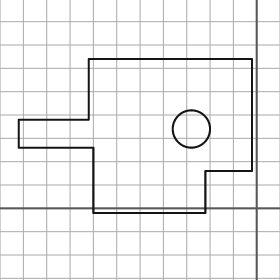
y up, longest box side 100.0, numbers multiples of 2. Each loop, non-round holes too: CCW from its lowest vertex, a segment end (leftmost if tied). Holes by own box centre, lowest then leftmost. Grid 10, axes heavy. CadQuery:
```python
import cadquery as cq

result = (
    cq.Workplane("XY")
    .moveTo(-70.0, -2.0)
    .lineTo(-22.0, -2.0)
    .lineTo(-22.0, 16.0)
    .lineTo(-2.0, 16.0)
    .lineTo(-2.0, 64.0)
    .lineTo(-72.0, 64.0)
    .lineTo(-72.0, 38.0)
    .lineTo(-102.0, 38.0)
    .lineTo(-102.0, 26.0)
    .lineTo(-70.0, 26.0)
    .close()
    .moveTo(-28.0, 34.0)
    .circle(8.0)
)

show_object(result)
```